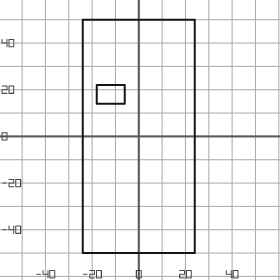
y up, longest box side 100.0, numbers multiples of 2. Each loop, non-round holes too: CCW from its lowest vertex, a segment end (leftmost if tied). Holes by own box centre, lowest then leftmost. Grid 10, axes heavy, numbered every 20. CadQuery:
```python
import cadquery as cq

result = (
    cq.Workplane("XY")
    .moveTo(-24.0, -50.0)
    .lineTo(24.0, -50.0)
    .lineTo(24.0, 50.0)
    .lineTo(-24.0, 50.0)
    .close()
    .moveTo(-18.0, 14.0)
    .lineTo(-6.0, 14.0)
    .lineTo(-6.0, 22.0)
    .lineTo(-18.0, 22.0)
    .close()
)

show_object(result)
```